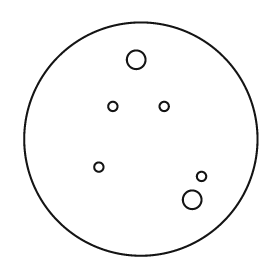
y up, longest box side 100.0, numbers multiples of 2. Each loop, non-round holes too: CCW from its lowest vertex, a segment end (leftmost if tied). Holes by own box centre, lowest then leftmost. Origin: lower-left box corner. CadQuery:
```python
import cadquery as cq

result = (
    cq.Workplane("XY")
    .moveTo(50.0, 50.0)
    .circle(50.0)
    .moveTo(72.0, 24.0)
    .circle(4.0)
    .moveTo(76.0, 34.0)
    .circle(2.0)
    .moveTo(32.0, 38.0)
    .circle(2.0)
    .moveTo(38.0, 64.0)
    .circle(2.0)
    .moveTo(60.0, 64.0)
    .circle(2.0)
    .moveTo(48.0, 84.0)
    .circle(4.0)
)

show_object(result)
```